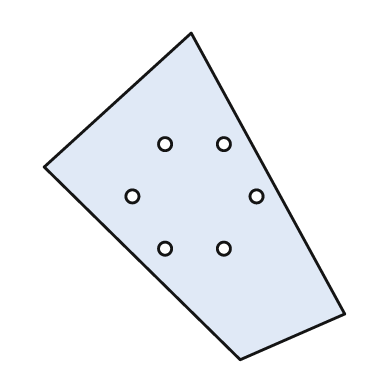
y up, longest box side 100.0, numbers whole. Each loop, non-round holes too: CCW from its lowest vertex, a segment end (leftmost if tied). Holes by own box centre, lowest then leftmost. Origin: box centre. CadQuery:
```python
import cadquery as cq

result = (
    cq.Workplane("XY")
    .moveTo(14.0, -50.0)
    .lineTo(46.0, -36.0)
    .lineTo(-1.0, 50.0)
    .lineTo(-46.0, 9.0)
    .close()
    .moveTo(-9.0, -16.0)
    .circle(2.0)
    .moveTo(9.0, -16.0)
    .circle(2.0)
    .moveTo(-19.0, 0.0)
    .circle(2.0)
    .moveTo(19.0, 0.0)
    .circle(2.0)
    .moveTo(-9.0, 16.0)
    .circle(2.0)
    .moveTo(9.0, 16.0)
    .circle(2.0)
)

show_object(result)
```